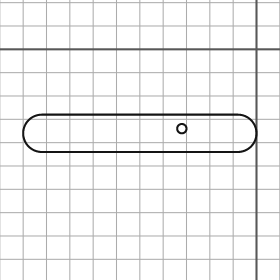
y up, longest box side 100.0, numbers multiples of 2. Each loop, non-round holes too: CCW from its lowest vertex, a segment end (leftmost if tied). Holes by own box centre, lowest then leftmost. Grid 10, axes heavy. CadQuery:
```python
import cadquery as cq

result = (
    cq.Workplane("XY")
    .moveTo(-92.0, -44.0)
    .lineTo(-8.0, -44.0)
    .threePointArc((0.0, -36.0), (-8.0, -28.0))
    .lineTo(-92.0, -28.0)
    .threePointArc((-100.0, -36.0), (-92.0, -44.0))
    .close()
    .moveTo(-32.0, -34.0)
    .circle(2.0)
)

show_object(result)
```